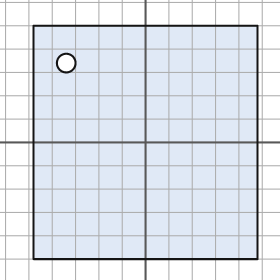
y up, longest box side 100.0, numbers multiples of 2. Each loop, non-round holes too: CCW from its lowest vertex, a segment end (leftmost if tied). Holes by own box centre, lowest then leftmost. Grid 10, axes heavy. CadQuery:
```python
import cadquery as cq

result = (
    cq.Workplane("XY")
    .moveTo(-48.0, -50.0)
    .lineTo(48.0, -50.0)
    .lineTo(48.0, 50.0)
    .lineTo(-48.0, 50.0)
    .close()
    .moveTo(-34.0, 34.0)
    .circle(4.0)
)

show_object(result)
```